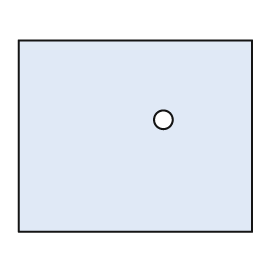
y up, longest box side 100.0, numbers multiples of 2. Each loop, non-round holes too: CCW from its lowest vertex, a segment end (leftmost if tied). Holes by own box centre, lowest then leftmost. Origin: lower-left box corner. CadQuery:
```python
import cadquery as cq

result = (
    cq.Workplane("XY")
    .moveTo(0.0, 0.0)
    .lineTo(100.0, 0.0)
    .lineTo(100.0, 82.0)
    .lineTo(0.0, 82.0)
    .close()
    .moveTo(62.0, 48.0)
    .circle(4.0)
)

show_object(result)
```